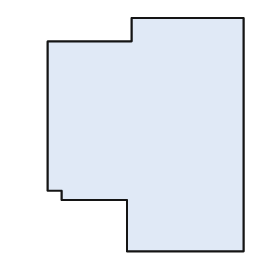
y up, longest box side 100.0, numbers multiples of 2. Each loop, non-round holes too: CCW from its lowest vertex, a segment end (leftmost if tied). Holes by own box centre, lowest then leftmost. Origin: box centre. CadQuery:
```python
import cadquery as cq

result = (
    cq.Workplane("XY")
    .moveTo(-8.0, -50.0)
    .lineTo(42.0, -50.0)
    .lineTo(42.0, 50.0)
    .lineTo(-6.0, 50.0)
    .lineTo(-6.0, 40.0)
    .lineTo(-42.0, 40.0)
    .lineTo(-42.0, -24.0)
    .lineTo(-36.0, -24.0)
    .lineTo(-36.0, -28.0)
    .lineTo(-8.0, -28.0)
    .close()
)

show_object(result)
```